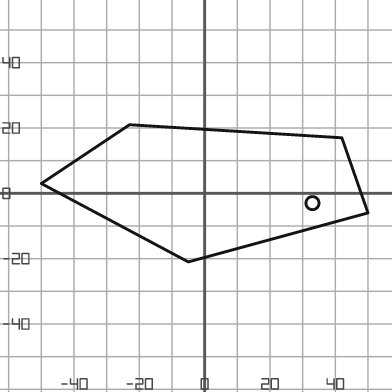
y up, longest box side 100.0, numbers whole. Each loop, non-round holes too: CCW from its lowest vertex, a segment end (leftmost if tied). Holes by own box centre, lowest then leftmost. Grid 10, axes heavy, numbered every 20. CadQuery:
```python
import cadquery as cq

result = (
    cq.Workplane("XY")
    .moveTo(-5.0, -21.0)
    .lineTo(50.0, -6.0)
    .lineTo(42.0, 17.0)
    .lineTo(-23.0, 21.0)
    .lineTo(-50.0, 3.0)
    .close()
    .moveTo(33.0, -3.0)
    .circle(2.0)
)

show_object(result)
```